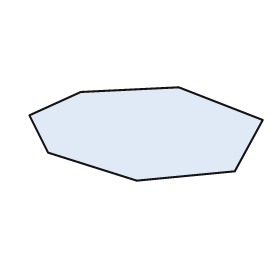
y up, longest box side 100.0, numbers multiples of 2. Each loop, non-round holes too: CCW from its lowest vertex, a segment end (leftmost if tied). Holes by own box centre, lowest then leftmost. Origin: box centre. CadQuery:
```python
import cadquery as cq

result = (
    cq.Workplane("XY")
    .moveTo(-4.0, -20.0)
    .lineTo(38.0, -16.0)
    .lineTo(50.0, 6.0)
    .lineTo(14.0, 20.0)
    .lineTo(-28.0, 18.0)
    .lineTo(-50.0, 8.0)
    .lineTo(-42.0, -8.0)
    .close()
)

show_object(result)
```